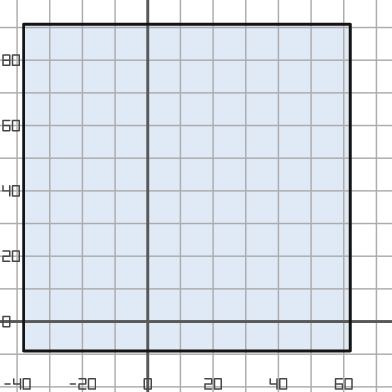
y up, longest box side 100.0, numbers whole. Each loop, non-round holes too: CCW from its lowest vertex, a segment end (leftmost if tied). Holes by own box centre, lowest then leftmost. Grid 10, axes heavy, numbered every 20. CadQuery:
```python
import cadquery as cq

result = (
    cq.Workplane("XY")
    .moveTo(-38.0, -9.0)
    .lineTo(62.0, -9.0)
    .lineTo(62.0, 91.0)
    .lineTo(-38.0, 91.0)
    .close()
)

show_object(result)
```